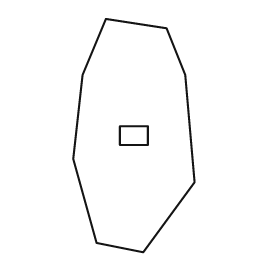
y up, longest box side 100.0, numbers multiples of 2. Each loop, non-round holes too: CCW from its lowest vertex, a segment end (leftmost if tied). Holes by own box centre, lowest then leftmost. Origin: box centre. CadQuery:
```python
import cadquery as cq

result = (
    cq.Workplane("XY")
    .moveTo(4.0, -50.0)
    .lineTo(26.0, -20.0)
    .lineTo(22.0, 26.0)
    .lineTo(14.0, 46.0)
    .lineTo(-12.0, 50.0)
    .lineTo(-22.0, 26.0)
    .lineTo(-26.0, -10.0)
    .lineTo(-16.0, -46.0)
    .close()
    .moveTo(-6.0, -4.0)
    .lineTo(6.0, -4.0)
    .lineTo(6.0, 4.0)
    .lineTo(-6.0, 4.0)
    .close()
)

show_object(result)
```